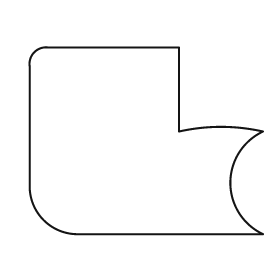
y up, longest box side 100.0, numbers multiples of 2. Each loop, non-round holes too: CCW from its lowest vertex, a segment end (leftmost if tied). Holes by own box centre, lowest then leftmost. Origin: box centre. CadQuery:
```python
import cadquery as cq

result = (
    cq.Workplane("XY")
    .moveTo(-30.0, -40.0)
    .lineTo(50.0, -40.0)
    .threePointArc((36.0, -18.0), (50.0, 4.0))
    .threePointArc((32.0, 6.0), (14.0, 4.0))
    .lineTo(14.0, 40.0)
    .lineTo(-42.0, 40.0)
    .threePointArc((-48.0, 38.0), (-50.0, 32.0))
    .lineTo(-50.0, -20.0)
    .threePointArc((-44.0, -34.0), (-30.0, -40.0))
    .close()
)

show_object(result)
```